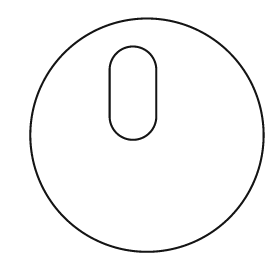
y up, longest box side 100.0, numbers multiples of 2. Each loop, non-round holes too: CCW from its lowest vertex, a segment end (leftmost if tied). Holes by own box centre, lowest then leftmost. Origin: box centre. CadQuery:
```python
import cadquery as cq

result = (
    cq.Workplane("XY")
    .moveTo(0.0, 0.0)
    .circle(50.0)
    .moveTo(-16.0, 8.0)
    .threePointArc((-6.0, -2.0), (4.0, 8.0))
    .lineTo(4.0, 28.0)
    .threePointArc((-6.0, 38.0), (-16.0, 28.0))
    .close()
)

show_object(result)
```